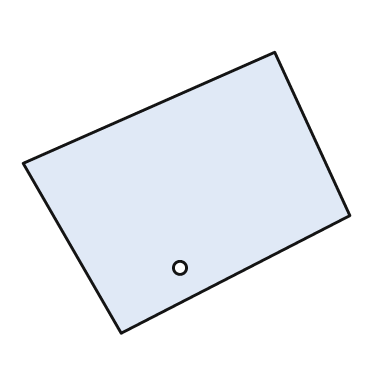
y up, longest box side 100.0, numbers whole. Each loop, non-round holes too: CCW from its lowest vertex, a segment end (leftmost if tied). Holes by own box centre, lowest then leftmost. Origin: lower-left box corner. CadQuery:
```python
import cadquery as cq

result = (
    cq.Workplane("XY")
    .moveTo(30.0, 0.0)
    .lineTo(100.0, 36.0)
    .lineTo(77.0, 86.0)
    .lineTo(0.0, 52.0)
    .close()
    .moveTo(48.0, 20.0)
    .circle(2.0)
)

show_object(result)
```